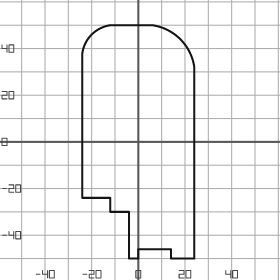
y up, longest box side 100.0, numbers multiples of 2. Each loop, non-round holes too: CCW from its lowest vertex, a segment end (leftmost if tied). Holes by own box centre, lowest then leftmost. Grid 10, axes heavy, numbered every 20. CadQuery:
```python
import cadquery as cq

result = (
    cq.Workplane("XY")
    .moveTo(-4.0, -50.0)
    .lineTo(0.0, -50.0)
    .lineTo(0.0, -46.0)
    .lineTo(14.0, -46.0)
    .lineTo(14.0, -50.0)
    .lineTo(24.0, -50.0)
    .lineTo(24.0, 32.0)
    .threePointArc((18.0, 44.0), (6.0, 50.0))
    .lineTo(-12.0, 50.0)
    .threePointArc((-20.0, 46.0), (-24.0, 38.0))
    .lineTo(-24.0, -24.0)
    .lineTo(-12.0, -24.0)
    .lineTo(-12.0, -30.0)
    .lineTo(-4.0, -30.0)
    .close()
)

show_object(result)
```